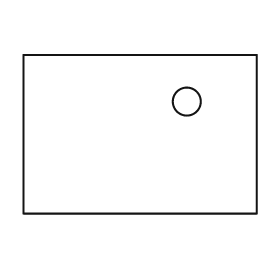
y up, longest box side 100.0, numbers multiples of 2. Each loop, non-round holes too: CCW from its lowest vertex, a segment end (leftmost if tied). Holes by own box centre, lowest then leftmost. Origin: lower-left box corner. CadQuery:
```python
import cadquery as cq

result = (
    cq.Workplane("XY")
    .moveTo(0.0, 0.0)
    .lineTo(100.0, 0.0)
    .lineTo(100.0, 68.0)
    .lineTo(0.0, 68.0)
    .close()
    .moveTo(70.0, 48.0)
    .circle(6.0)
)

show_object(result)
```